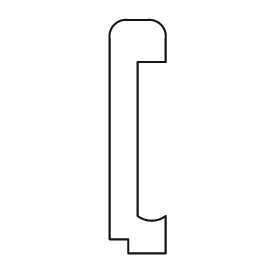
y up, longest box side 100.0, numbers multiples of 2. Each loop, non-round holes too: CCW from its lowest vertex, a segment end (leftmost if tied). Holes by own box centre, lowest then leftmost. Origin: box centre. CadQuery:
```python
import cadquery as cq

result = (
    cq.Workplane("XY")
    .moveTo(-4.0, -50.0)
    .lineTo(12.0, -50.0)
    .lineTo(12.0, -34.0)
    .threePointArc((6.0, -36.0), (0.0, -34.0))
    .lineTo(0.0, 32.0)
    .lineTo(12.0, 32.0)
    .lineTo(12.0, 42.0)
    .threePointArc((10.0, 48.0), (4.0, 50.0))
    .lineTo(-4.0, 50.0)
    .threePointArc((-10.0, 48.0), (-12.0, 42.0))
    .lineTo(-12.0, -44.0)
    .lineTo(-4.0, -44.0)
    .close()
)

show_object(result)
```